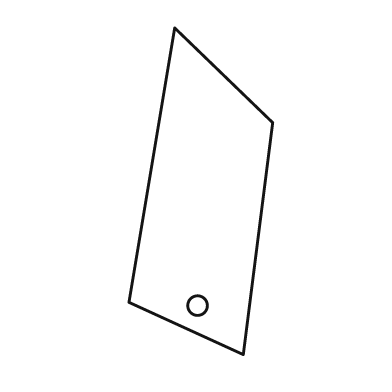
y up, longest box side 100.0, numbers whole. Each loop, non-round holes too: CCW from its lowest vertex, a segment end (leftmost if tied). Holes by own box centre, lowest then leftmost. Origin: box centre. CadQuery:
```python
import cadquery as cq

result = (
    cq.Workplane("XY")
    .moveTo(13.0, -50.0)
    .lineTo(22.0, 21.0)
    .lineTo(-8.0, 50.0)
    .lineTo(-22.0, -34.0)
    .close()
    .moveTo(-1.0, -35.0)
    .circle(3.0)
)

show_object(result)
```